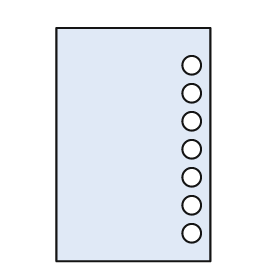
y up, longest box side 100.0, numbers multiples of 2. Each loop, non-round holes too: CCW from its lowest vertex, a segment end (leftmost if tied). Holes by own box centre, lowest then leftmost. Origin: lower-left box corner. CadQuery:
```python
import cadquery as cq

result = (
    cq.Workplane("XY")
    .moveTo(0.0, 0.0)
    .lineTo(66.0, 0.0)
    .lineTo(66.0, 100.0)
    .lineTo(0.0, 100.0)
    .close()
    .moveTo(58.0, 12.0)
    .circle(4.0)
    .moveTo(58.0, 24.0)
    .circle(4.0)
    .moveTo(58.0, 36.0)
    .circle(4.0)
    .moveTo(58.0, 48.0)
    .circle(4.0)
    .moveTo(58.0, 60.0)
    .circle(4.0)
    .moveTo(58.0, 72.0)
    .circle(4.0)
    .moveTo(58.0, 84.0)
    .circle(4.0)
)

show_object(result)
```